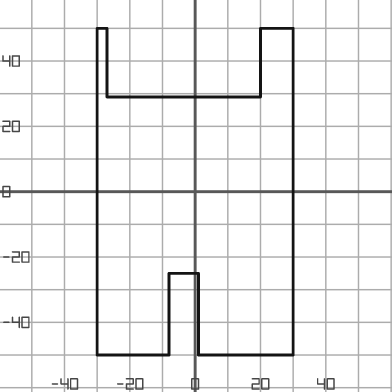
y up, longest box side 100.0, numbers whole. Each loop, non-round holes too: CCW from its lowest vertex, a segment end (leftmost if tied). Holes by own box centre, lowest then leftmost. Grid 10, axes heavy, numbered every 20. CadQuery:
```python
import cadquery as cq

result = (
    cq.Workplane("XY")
    .moveTo(-30.0, -50.0)
    .lineTo(-8.0, -50.0)
    .lineTo(-8.0, -25.0)
    .lineTo(1.0, -25.0)
    .lineTo(1.0, -50.0)
    .lineTo(30.0, -50.0)
    .lineTo(30.0, 50.0)
    .lineTo(20.0, 50.0)
    .lineTo(20.0, 29.0)
    .lineTo(-27.0, 29.0)
    .lineTo(-27.0, 50.0)
    .lineTo(-30.0, 50.0)
    .close()
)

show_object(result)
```